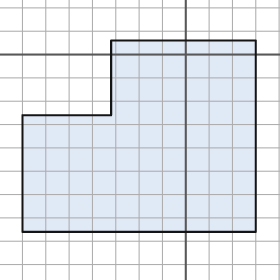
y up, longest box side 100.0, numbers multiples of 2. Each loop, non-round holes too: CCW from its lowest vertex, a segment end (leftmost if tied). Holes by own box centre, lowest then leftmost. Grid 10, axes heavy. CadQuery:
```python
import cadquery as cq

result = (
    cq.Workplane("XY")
    .moveTo(-70.0, -76.0)
    .lineTo(30.0, -76.0)
    .lineTo(30.0, 6.0)
    .lineTo(-32.0, 6.0)
    .lineTo(-32.0, -26.0)
    .lineTo(-70.0, -26.0)
    .close()
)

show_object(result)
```